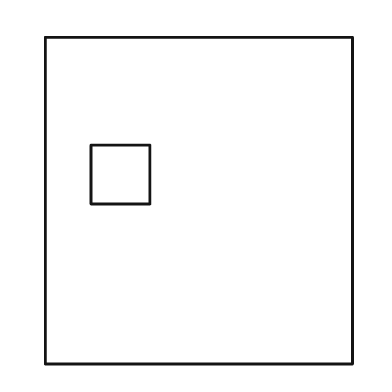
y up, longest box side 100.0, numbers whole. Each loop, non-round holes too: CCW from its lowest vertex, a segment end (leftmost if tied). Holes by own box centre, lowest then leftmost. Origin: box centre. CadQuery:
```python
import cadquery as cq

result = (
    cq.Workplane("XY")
    .moveTo(-47.0, -50.0)
    .lineTo(47.0, -50.0)
    .lineTo(47.0, 50.0)
    .lineTo(-47.0, 50.0)
    .close()
    .moveTo(-33.0, -1.0)
    .lineTo(-15.0, -1.0)
    .lineTo(-15.0, 17.0)
    .lineTo(-33.0, 17.0)
    .close()
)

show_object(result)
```